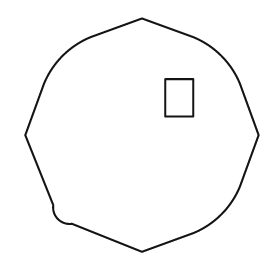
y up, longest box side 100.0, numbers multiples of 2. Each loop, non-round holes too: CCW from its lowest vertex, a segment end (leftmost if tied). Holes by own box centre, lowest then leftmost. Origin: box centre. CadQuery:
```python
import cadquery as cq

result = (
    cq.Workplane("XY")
    .moveTo(0.0, -50.0)
    .lineTo(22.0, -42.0)
    .threePointArc((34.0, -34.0), (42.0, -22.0))
    .lineTo(50.0, 0.0)
    .lineTo(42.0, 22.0)
    .threePointArc((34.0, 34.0), (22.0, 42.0))
    .lineTo(0.0, 50.0)
    .lineTo(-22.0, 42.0)
    .threePointArc((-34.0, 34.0), (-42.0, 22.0))
    .lineTo(-50.0, 0.0)
    .lineTo(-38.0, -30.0)
    .threePointArc((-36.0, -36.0), (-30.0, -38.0))
    .close()
    .moveTo(10.0, 8.0)
    .lineTo(22.0, 8.0)
    .lineTo(22.0, 24.0)
    .lineTo(10.0, 24.0)
    .close()
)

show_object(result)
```